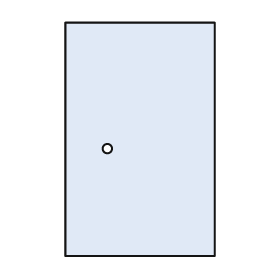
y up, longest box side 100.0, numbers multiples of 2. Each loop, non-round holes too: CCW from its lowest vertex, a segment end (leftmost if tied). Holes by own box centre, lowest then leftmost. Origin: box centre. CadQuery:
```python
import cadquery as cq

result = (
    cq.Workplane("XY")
    .moveTo(-32.0, -50.0)
    .lineTo(32.0, -50.0)
    .lineTo(32.0, 50.0)
    .lineTo(-32.0, 50.0)
    .close()
    .moveTo(-14.0, -4.0)
    .circle(2.0)
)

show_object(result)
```